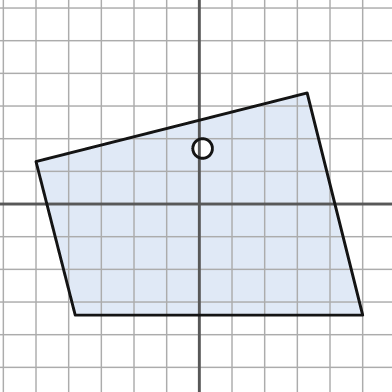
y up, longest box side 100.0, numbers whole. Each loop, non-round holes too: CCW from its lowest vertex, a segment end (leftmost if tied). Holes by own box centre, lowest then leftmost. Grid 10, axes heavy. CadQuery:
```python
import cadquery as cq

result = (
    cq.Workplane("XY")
    .moveTo(-38.0, -34.0)
    .lineTo(50.0, -34.0)
    .lineTo(33.0, 34.0)
    .lineTo(-50.0, 13.0)
    .close()
    .moveTo(1.0, 17.0)
    .circle(3.0)
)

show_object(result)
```